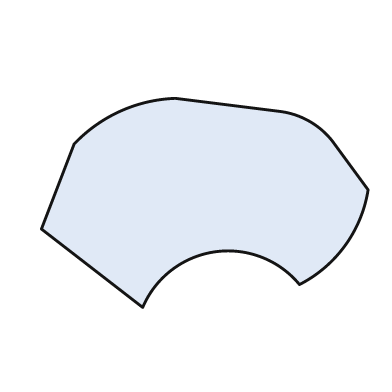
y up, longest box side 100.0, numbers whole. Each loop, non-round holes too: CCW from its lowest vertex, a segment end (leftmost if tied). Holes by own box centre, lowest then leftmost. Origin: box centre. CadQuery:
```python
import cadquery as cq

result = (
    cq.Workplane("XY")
    .moveTo(-19.0, -32.0)
    .threePointArc((3.0, -15.0), (29.0, -25.0))
    .threePointArc((43.0, -13.0), (50.0, 4.0))
    .lineTo(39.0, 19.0)
    .threePointArc((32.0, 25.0), (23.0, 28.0))
    .lineTo(-9.0, 32.0)
    .threePointArc((-26.0, 28.0), (-40.0, 18.0))
    .lineTo(-50.0, -8.0)
    .close()
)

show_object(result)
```